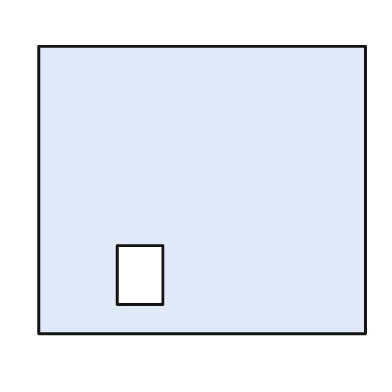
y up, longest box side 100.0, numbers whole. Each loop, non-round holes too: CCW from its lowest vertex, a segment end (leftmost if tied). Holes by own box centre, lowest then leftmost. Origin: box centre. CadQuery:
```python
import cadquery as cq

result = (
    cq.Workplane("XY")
    .moveTo(-50.0, -44.0)
    .lineTo(50.0, -44.0)
    .lineTo(50.0, 44.0)
    .lineTo(-50.0, 44.0)
    .close()
    .moveTo(-26.0, -35.0)
    .lineTo(-12.0, -35.0)
    .lineTo(-12.0, -17.0)
    .lineTo(-26.0, -17.0)
    .close()
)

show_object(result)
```